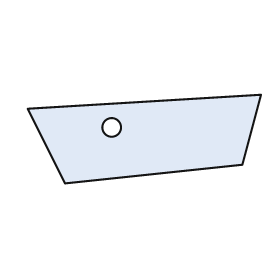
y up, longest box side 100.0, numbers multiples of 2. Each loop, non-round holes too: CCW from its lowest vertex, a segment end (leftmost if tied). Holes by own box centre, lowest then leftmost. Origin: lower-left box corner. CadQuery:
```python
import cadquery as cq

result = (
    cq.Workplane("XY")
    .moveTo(16.0, 0.0)
    .lineTo(92.0, 8.0)
    .lineTo(100.0, 38.0)
    .lineTo(0.0, 32.0)
    .close()
    .moveTo(36.0, 24.0)
    .circle(4.0)
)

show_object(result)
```